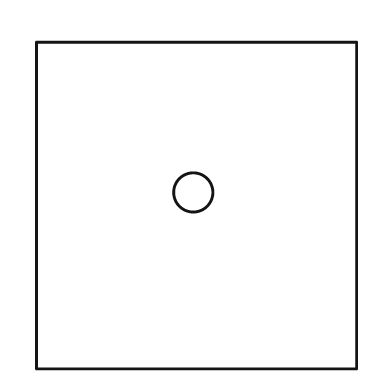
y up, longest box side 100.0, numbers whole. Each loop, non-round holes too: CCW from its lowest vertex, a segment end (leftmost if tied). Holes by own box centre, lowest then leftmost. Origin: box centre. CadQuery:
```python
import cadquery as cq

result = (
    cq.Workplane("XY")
    .moveTo(-49.0, -50.0)
    .lineTo(49.0, -50.0)
    .lineTo(49.0, 50.0)
    .lineTo(-49.0, 50.0)
    .close()
    .moveTo(-1.0, 4.0)
    .circle(6.0)
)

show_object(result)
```